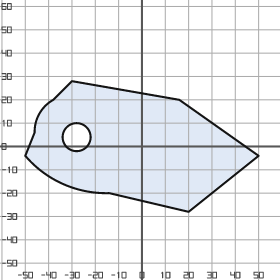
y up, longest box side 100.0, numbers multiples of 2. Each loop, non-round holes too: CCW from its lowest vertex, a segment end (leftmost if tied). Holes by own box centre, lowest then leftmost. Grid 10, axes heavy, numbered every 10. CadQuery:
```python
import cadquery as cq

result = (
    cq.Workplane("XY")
    .moveTo(20.0, -28.0)
    .lineTo(50.0, -4.0)
    .lineTo(16.0, 20.0)
    .lineTo(-30.0, 28.0)
    .lineTo(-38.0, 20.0)
    .threePointArc((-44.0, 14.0), (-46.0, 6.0))
    .lineTo(-50.0, -4.0)
    .threePointArc((-34.0, -16.0), (-14.0, -20.0))
    .close()
    .moveTo(-28.0, 4.0)
    .circle(6.0)
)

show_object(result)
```